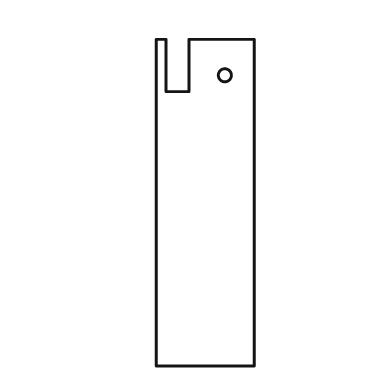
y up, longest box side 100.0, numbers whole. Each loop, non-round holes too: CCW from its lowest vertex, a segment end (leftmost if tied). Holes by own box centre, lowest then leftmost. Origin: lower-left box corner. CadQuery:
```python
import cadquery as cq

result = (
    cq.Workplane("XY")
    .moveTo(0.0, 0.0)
    .lineTo(30.0, 0.0)
    .lineTo(30.0, 100.0)
    .lineTo(10.0, 100.0)
    .lineTo(10.0, 84.0)
    .lineTo(3.0, 84.0)
    .lineTo(3.0, 100.0)
    .lineTo(0.0, 100.0)
    .close()
    .moveTo(21.0, 89.0)
    .circle(2.0)
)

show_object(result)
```